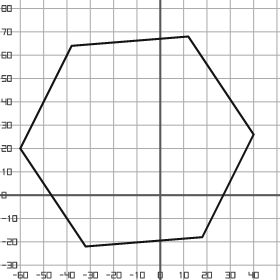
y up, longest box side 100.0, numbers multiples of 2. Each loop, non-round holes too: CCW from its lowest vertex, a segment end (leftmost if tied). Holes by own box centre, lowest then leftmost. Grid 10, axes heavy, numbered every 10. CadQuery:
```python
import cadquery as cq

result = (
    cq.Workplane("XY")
    .moveTo(-32.0, -22.0)
    .lineTo(18.0, -18.0)
    .lineTo(40.0, 26.0)
    .lineTo(12.0, 68.0)
    .lineTo(-38.0, 64.0)
    .lineTo(-60.0, 20.0)
    .close()
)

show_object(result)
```